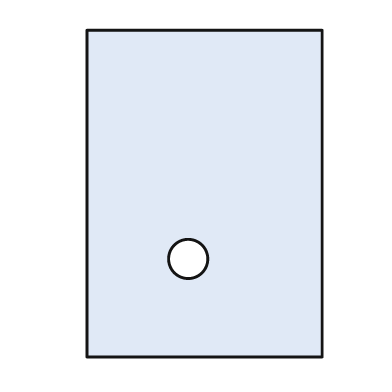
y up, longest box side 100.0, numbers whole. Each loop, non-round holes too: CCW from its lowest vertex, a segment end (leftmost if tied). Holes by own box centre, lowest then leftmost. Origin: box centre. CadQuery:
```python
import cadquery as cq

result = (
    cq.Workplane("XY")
    .moveTo(-36.0, -50.0)
    .lineTo(36.0, -50.0)
    .lineTo(36.0, 50.0)
    .lineTo(-36.0, 50.0)
    .close()
    .moveTo(-5.0, -20.0)
    .circle(6.0)
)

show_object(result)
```